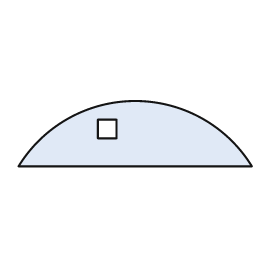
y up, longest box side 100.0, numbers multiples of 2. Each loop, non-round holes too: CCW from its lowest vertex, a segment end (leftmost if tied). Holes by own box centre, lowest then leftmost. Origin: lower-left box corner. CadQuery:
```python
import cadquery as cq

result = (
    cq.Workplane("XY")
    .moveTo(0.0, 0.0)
    .lineTo(100.0, 0.0)
    .threePointArc((50.0, 28.0), (0.0, 0.0))
    .close()
    .moveTo(34.0, 12.0)
    .lineTo(42.0, 12.0)
    .lineTo(42.0, 20.0)
    .lineTo(34.0, 20.0)
    .close()
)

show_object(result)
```